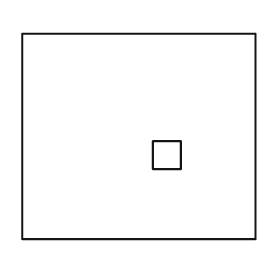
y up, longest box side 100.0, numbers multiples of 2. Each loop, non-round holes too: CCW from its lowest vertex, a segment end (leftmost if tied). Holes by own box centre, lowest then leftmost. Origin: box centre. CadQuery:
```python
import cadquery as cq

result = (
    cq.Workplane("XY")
    .moveTo(-50.0, -44.0)
    .lineTo(50.0, -44.0)
    .lineTo(50.0, 44.0)
    .lineTo(-50.0, 44.0)
    .close()
    .moveTo(6.0, -14.0)
    .lineTo(18.0, -14.0)
    .lineTo(18.0, -2.0)
    .lineTo(6.0, -2.0)
    .close()
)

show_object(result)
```